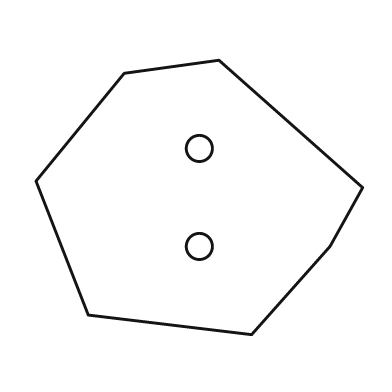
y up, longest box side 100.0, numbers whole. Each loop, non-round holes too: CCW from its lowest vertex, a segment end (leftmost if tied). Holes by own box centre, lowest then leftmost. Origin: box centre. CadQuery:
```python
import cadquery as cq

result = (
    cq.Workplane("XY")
    .moveTo(16.0, -42.0)
    .lineTo(40.0, -15.0)
    .lineTo(50.0, 3.0)
    .lineTo(6.0, 42.0)
    .lineTo(-23.0, 38.0)
    .lineTo(-50.0, 5.0)
    .lineTo(-34.0, -36.0)
    .close()
    .moveTo(0.0, -15.0)
    .circle(4.0)
    .moveTo(0.0, 15.0)
    .circle(4.0)
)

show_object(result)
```